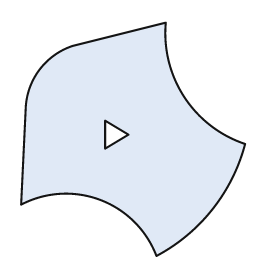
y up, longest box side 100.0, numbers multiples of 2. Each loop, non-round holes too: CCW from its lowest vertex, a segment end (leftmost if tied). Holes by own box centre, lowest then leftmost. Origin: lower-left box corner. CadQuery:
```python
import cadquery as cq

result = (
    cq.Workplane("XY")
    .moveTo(58.0, 0.0)
    .threePointArc((82.0, 20.0), (96.0, 48.0))
    .threePointArc((70.0, 68.0), (62.0, 100.0))
    .lineTo(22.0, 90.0)
    .threePointArc((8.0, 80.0), (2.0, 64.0))
    .lineTo(0.0, 22.0)
    .threePointArc((34.0, 24.0), (58.0, 0.0))
    .close()
    .moveTo(36.0, 46.0)
    .lineTo(46.0, 52.0)
    .lineTo(36.0, 58.0)
    .close()
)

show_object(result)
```